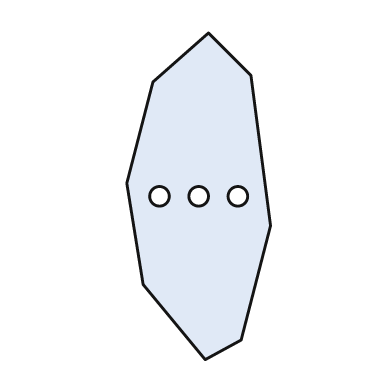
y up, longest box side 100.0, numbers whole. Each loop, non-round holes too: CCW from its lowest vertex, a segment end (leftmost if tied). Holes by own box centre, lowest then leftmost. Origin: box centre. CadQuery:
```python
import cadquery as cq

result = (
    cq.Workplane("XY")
    .moveTo(2.0, -50.0)
    .lineTo(13.0, -44.0)
    .lineTo(22.0, -9.0)
    .lineTo(16.0, 37.0)
    .lineTo(3.0, 50.0)
    .lineTo(-14.0, 35.0)
    .lineTo(-22.0, 4.0)
    .lineTo(-17.0, -27.0)
    .close()
    .moveTo(-12.0, 0.0)
    .circle(3.0)
    .moveTo(0.0, 0.0)
    .circle(3.0)
    .moveTo(12.0, 0.0)
    .circle(3.0)
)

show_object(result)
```